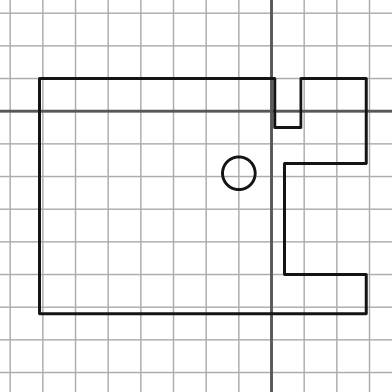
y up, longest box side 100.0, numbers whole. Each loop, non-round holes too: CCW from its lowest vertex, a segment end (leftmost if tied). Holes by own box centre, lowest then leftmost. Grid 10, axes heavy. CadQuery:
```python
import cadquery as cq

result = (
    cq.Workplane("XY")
    .moveTo(-71.0, -62.0)
    .lineTo(29.0, -62.0)
    .lineTo(29.0, -50.0)
    .lineTo(4.0, -50.0)
    .lineTo(4.0, -16.0)
    .lineTo(29.0, -16.0)
    .lineTo(29.0, 10.0)
    .lineTo(9.0, 10.0)
    .lineTo(9.0, -5.0)
    .lineTo(1.0, -5.0)
    .lineTo(1.0, 10.0)
    .lineTo(-71.0, 10.0)
    .close()
    .moveTo(-10.0, -19.0)
    .circle(5.0)
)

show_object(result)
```